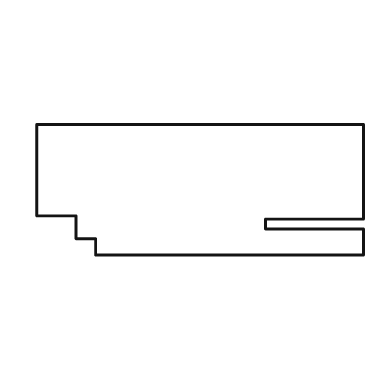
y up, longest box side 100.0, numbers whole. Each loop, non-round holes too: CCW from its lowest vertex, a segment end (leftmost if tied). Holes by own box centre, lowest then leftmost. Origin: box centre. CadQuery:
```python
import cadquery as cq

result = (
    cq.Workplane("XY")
    .moveTo(-32.0, -20.0)
    .lineTo(50.0, -20.0)
    .lineTo(50.0, -12.0)
    .lineTo(20.0, -12.0)
    .lineTo(20.0, -9.0)
    .lineTo(50.0, -9.0)
    .lineTo(50.0, 20.0)
    .lineTo(-50.0, 20.0)
    .lineTo(-50.0, -8.0)
    .lineTo(-38.0, -8.0)
    .lineTo(-38.0, -15.0)
    .lineTo(-32.0, -15.0)
    .close()
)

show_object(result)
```